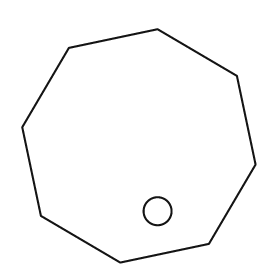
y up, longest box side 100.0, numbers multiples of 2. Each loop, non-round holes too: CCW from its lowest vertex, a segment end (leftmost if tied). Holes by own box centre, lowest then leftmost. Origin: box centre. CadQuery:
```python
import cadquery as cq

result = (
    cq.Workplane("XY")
    .moveTo(-8.0, -50.0)
    .lineTo(30.0, -42.0)
    .lineTo(50.0, -8.0)
    .lineTo(42.0, 30.0)
    .lineTo(8.0, 50.0)
    .lineTo(-30.0, 42.0)
    .lineTo(-50.0, 8.0)
    .lineTo(-42.0, -30.0)
    .close()
    .moveTo(8.0, -28.0)
    .circle(6.0)
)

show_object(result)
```